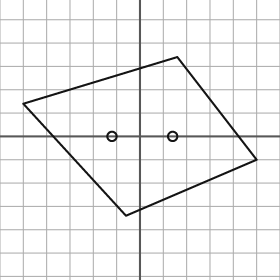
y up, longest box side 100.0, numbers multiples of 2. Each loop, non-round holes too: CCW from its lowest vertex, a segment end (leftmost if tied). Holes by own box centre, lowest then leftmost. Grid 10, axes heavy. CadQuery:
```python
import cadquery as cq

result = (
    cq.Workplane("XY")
    .moveTo(-6.0, -34.0)
    .lineTo(50.0, -10.0)
    .lineTo(16.0, 34.0)
    .lineTo(-50.0, 14.0)
    .close()
    .moveTo(-12.0, 0.0)
    .circle(2.0)
    .moveTo(14.0, 0.0)
    .circle(2.0)
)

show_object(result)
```